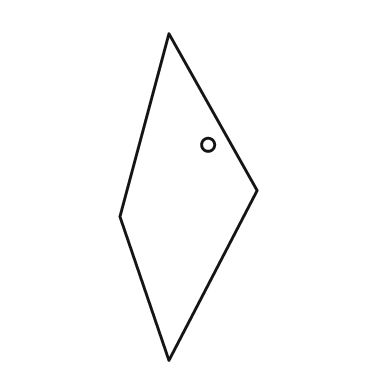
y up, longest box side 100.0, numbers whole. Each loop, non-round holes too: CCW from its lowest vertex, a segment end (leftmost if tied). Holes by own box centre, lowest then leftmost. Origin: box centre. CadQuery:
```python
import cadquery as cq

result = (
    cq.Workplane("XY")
    .moveTo(-6.0, -50.0)
    .lineTo(21.0, 2.0)
    .lineTo(-6.0, 50.0)
    .lineTo(-21.0, -6.0)
    .close()
    .moveTo(6.0, 16.0)
    .circle(2.0)
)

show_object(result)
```